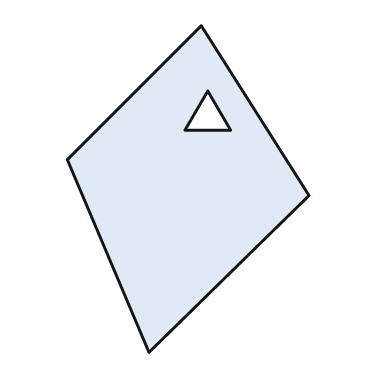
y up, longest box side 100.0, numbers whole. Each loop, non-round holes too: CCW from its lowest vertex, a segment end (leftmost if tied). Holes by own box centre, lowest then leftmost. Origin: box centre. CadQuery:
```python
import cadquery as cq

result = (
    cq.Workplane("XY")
    .moveTo(-12.0, -50.0)
    .lineTo(37.0, -2.0)
    .lineTo(4.0, 50.0)
    .lineTo(-37.0, 9.0)
    .close()
    .moveTo(-1.0, 18.0)
    .lineTo(13.0, 18.0)
    .lineTo(6.0, 30.0)
    .close()
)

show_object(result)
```